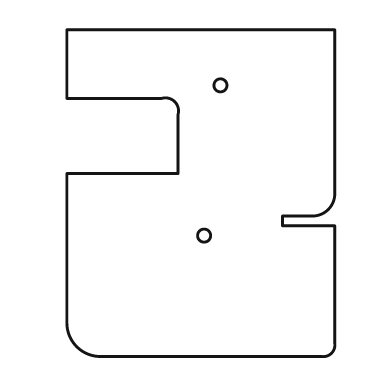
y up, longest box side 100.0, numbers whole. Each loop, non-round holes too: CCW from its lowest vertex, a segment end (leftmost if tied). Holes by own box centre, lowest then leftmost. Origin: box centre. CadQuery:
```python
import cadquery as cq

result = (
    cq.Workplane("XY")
    .moveTo(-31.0, -50.0)
    .lineTo(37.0, -50.0)
    .threePointArc((40.0, -49.0), (41.0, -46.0))
    .lineTo(41.0, -10.0)
    .lineTo(25.0, -10.0)
    .lineTo(25.0, -7.0)
    .lineTo(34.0, -7.0)
    .threePointArc((39.0, -5.0), (41.0, 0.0))
    .lineTo(41.0, 50.0)
    .lineTo(-41.0, 50.0)
    .lineTo(-41.0, 29.0)
    .lineTo(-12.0, 29.0)
    .threePointArc((-8.0, 28.0), (-7.0, 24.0))
    .lineTo(-7.0, 6.0)
    .lineTo(-41.0, 6.0)
    .lineTo(-41.0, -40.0)
    .threePointArc((-38.0, -47.0), (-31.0, -50.0))
    .close()
    .moveTo(1.0, -13.0)
    .circle(2.0)
    .moveTo(6.0, 33.0)
    .circle(2.0)
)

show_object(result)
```